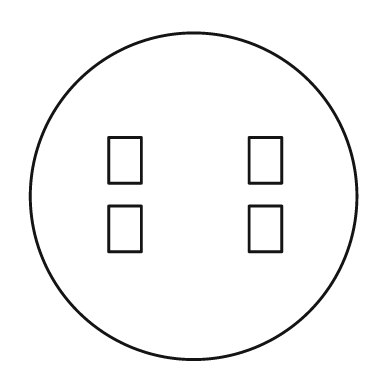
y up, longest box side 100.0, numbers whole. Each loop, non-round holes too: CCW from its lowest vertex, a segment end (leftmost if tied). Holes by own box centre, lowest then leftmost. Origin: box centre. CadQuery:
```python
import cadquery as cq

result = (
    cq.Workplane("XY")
    .moveTo(0.0, 0.0)
    .circle(50.0)
    .moveTo(-26.0, -17.0)
    .lineTo(-16.0, -17.0)
    .lineTo(-16.0, -3.0)
    .lineTo(-26.0, -3.0)
    .close()
    .moveTo(17.0, -17.0)
    .lineTo(27.0, -17.0)
    .lineTo(27.0, -3.0)
    .lineTo(17.0, -3.0)
    .close()
    .moveTo(-26.0, 4.0)
    .lineTo(-16.0, 4.0)
    .lineTo(-16.0, 18.0)
    .lineTo(-26.0, 18.0)
    .close()
    .moveTo(17.0, 4.0)
    .lineTo(27.0, 4.0)
    .lineTo(27.0, 18.0)
    .lineTo(17.0, 18.0)
    .close()
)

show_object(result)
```